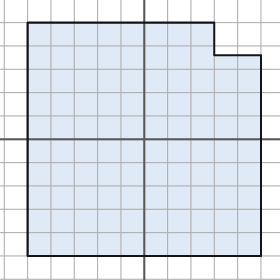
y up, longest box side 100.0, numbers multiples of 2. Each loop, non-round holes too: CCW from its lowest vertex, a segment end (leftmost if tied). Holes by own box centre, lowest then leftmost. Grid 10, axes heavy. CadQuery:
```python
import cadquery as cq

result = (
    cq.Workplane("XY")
    .moveTo(-50.0, -50.0)
    .lineTo(50.0, -50.0)
    .lineTo(50.0, 36.0)
    .lineTo(30.0, 36.0)
    .lineTo(30.0, 50.0)
    .lineTo(-50.0, 50.0)
    .close()
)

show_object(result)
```